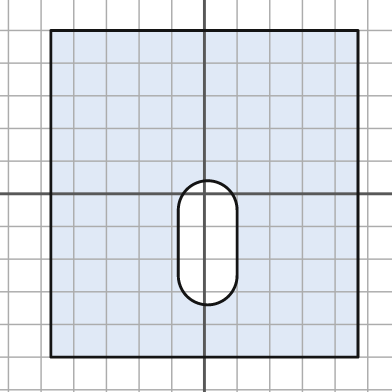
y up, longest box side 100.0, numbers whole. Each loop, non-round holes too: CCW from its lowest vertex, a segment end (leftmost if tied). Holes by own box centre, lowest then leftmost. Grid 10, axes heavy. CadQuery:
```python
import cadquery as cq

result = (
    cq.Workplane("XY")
    .moveTo(-47.0, -50.0)
    .lineTo(47.0, -50.0)
    .lineTo(47.0, 50.0)
    .lineTo(-47.0, 50.0)
    .close()
    .moveTo(-8.0, -25.0)
    .threePointArc((1.0, -34.0), (10.0, -25.0))
    .lineTo(10.0, -5.0)
    .threePointArc((1.0, 4.0), (-8.0, -5.0))
    .close()
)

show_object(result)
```